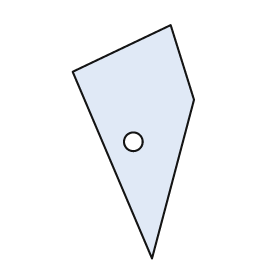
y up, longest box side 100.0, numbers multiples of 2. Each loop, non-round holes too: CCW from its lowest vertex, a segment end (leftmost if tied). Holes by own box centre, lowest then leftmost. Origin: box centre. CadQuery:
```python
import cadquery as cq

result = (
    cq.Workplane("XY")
    .moveTo(8.0, -50.0)
    .lineTo(26.0, 18.0)
    .lineTo(16.0, 50.0)
    .lineTo(-26.0, 30.0)
    .close()
    .moveTo(0.0, 0.0)
    .circle(4.0)
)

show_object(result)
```